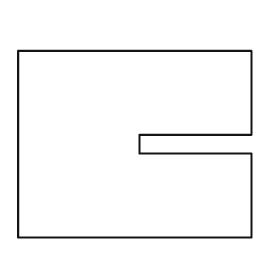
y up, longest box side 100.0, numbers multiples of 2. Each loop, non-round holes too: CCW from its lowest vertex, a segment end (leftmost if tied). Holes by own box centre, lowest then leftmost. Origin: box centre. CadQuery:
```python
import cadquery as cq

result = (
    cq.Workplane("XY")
    .moveTo(-50.0, -40.0)
    .lineTo(50.0, -40.0)
    .lineTo(50.0, -4.0)
    .lineTo(2.0, -4.0)
    .lineTo(2.0, 4.0)
    .lineTo(50.0, 4.0)
    .lineTo(50.0, 40.0)
    .lineTo(-50.0, 40.0)
    .close()
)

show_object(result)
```